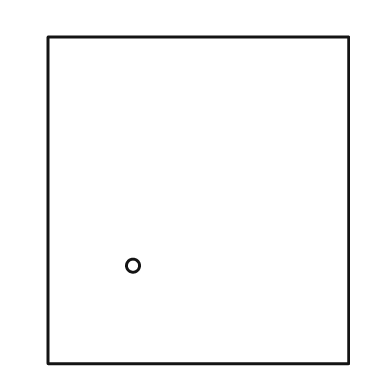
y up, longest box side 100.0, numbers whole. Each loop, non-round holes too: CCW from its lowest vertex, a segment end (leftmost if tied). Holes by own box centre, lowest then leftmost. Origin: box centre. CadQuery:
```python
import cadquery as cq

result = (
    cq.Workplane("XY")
    .moveTo(-46.0, -50.0)
    .lineTo(46.0, -50.0)
    .lineTo(46.0, 50.0)
    .lineTo(-46.0, 50.0)
    .close()
    .moveTo(-20.0, -20.0)
    .circle(2.0)
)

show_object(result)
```